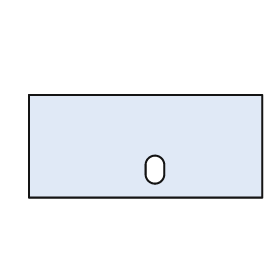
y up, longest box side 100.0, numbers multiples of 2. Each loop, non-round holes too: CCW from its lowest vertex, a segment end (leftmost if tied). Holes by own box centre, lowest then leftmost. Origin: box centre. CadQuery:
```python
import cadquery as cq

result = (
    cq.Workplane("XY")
    .moveTo(-50.0, -22.0)
    .lineTo(50.0, -22.0)
    .lineTo(50.0, 22.0)
    .lineTo(-50.0, 22.0)
    .close()
    .moveTo(0.0, -12.0)
    .threePointArc((4.0, -16.0), (8.0, -12.0))
    .lineTo(8.0, -8.0)
    .threePointArc((4.0, -4.0), (0.0, -8.0))
    .close()
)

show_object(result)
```